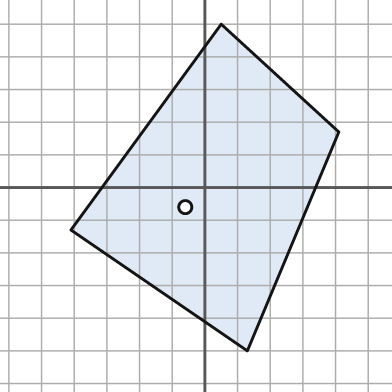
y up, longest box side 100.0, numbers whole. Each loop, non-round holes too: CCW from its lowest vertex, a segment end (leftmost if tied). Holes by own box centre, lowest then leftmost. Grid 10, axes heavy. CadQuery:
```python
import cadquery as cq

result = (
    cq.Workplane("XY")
    .moveTo(13.0, -50.0)
    .lineTo(41.0, 17.0)
    .lineTo(5.0, 50.0)
    .lineTo(-41.0, -13.0)
    .close()
    .moveTo(-6.0, -6.0)
    .circle(2.0)
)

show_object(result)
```